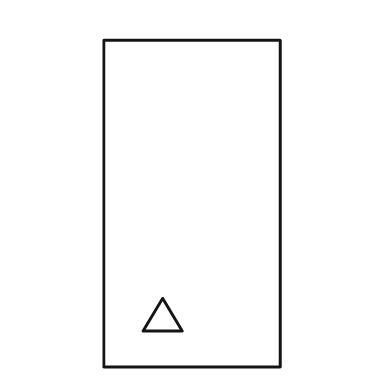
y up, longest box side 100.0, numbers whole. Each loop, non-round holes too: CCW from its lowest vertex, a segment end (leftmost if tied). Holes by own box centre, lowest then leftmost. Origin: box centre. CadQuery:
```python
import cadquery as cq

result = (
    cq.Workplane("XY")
    .moveTo(-27.0, -50.0)
    .lineTo(27.0, -50.0)
    .lineTo(27.0, 50.0)
    .lineTo(-27.0, 50.0)
    .close()
    .moveTo(-15.0, -39.0)
    .lineTo(-3.0, -39.0)
    .lineTo(-9.0, -29.0)
    .close()
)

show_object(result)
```